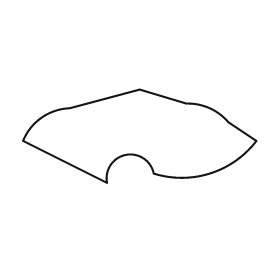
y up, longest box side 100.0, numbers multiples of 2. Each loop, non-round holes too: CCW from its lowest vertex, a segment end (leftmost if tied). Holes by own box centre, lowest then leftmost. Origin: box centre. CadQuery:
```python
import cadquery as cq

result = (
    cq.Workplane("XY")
    .moveTo(-14.0, -20.0)
    .threePointArc((-6.0, -8.0), (6.0, -16.0))
    .threePointArc((30.0, -16.0), (50.0, -2.0))
    .lineTo(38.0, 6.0)
    .threePointArc((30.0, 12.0), (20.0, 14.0))
    .lineTo(0.0, 20.0)
    .lineTo(-30.0, 12.0)
    .threePointArc((-42.0, 8.0), (-50.0, -2.0))
    .close()
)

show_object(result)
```